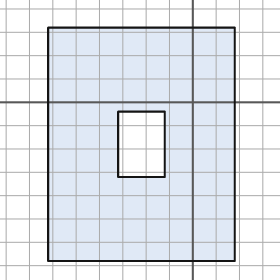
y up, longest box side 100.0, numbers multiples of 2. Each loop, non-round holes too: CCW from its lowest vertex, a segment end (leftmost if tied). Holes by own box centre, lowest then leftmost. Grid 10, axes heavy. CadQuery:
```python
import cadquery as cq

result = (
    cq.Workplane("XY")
    .moveTo(-62.0, -68.0)
    .lineTo(18.0, -68.0)
    .lineTo(18.0, 32.0)
    .lineTo(-62.0, 32.0)
    .close()
    .moveTo(-32.0, -32.0)
    .lineTo(-12.0, -32.0)
    .lineTo(-12.0, -4.0)
    .lineTo(-32.0, -4.0)
    .close()
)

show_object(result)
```